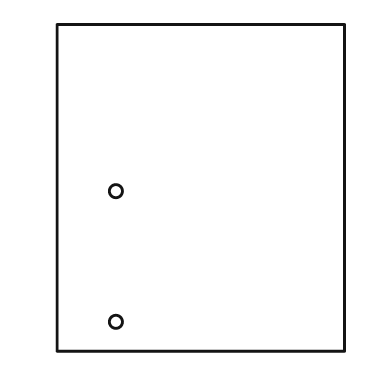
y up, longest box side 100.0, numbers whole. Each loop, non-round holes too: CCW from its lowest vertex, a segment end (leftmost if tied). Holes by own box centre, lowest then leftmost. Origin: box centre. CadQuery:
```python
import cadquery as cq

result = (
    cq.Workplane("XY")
    .moveTo(-44.0, -50.0)
    .lineTo(44.0, -50.0)
    .lineTo(44.0, 50.0)
    .lineTo(-44.0, 50.0)
    .close()
    .moveTo(-26.0, -41.0)
    .circle(2.0)
    .moveTo(-26.0, -1.0)
    .circle(2.0)
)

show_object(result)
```